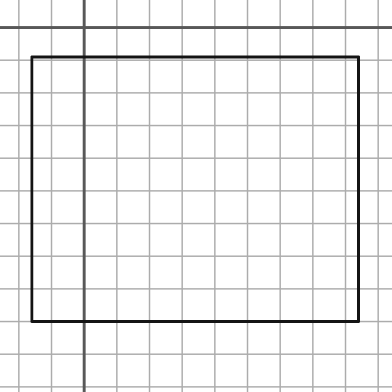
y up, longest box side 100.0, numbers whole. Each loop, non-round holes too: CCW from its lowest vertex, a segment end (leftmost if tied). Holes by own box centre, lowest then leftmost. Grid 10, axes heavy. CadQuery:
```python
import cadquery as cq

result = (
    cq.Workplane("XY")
    .moveTo(-16.0, -90.0)
    .lineTo(84.0, -90.0)
    .lineTo(84.0, -9.0)
    .lineTo(-16.0, -9.0)
    .close()
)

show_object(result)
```